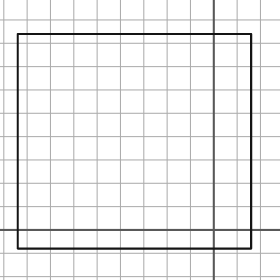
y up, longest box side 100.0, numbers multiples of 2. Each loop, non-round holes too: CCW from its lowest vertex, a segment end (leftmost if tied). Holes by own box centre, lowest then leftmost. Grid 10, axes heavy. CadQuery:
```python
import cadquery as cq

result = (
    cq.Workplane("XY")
    .moveTo(-84.0, -8.0)
    .lineTo(16.0, -8.0)
    .lineTo(16.0, 84.0)
    .lineTo(-84.0, 84.0)
    .close()
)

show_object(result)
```